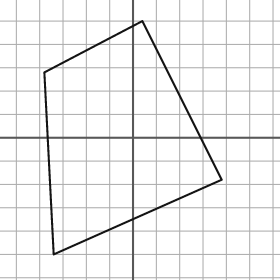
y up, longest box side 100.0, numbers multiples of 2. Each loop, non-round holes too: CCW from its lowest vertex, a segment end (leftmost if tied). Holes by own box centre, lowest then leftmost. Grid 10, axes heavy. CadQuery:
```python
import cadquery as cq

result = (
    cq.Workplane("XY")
    .moveTo(-34.0, -50.0)
    .lineTo(38.0, -18.0)
    .lineTo(4.0, 50.0)
    .lineTo(-38.0, 28.0)
    .close()
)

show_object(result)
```